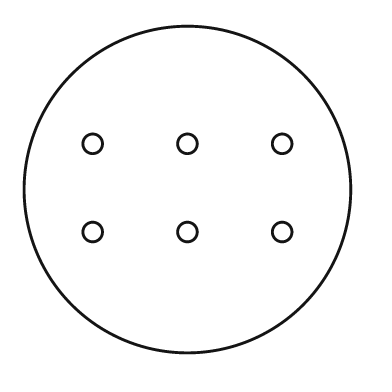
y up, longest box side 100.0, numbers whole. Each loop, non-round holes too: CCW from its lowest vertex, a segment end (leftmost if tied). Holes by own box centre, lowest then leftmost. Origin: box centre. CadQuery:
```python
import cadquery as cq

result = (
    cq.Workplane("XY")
    .moveTo(0.0, 0.0)
    .circle(50.0)
    .moveTo(-29.0, -13.0)
    .circle(3.0)
    .moveTo(0.0, -13.0)
    .circle(3.0)
    .moveTo(29.0, -13.0)
    .circle(3.0)
    .moveTo(-29.0, 14.0)
    .circle(3.0)
    .moveTo(0.0, 14.0)
    .circle(3.0)
    .moveTo(29.0, 14.0)
    .circle(3.0)
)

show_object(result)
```